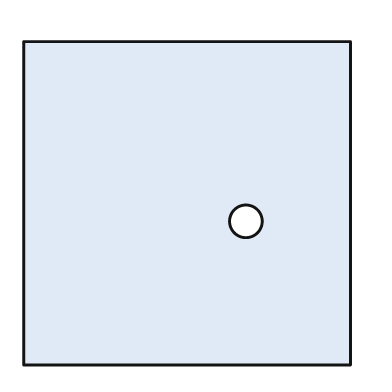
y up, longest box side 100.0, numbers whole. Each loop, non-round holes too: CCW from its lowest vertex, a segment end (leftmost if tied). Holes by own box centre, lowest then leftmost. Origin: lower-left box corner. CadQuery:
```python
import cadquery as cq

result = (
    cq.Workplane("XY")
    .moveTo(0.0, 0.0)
    .lineTo(100.0, 0.0)
    .lineTo(100.0, 99.0)
    .lineTo(0.0, 99.0)
    .close()
    .moveTo(68.0, 44.0)
    .circle(5.0)
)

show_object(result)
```